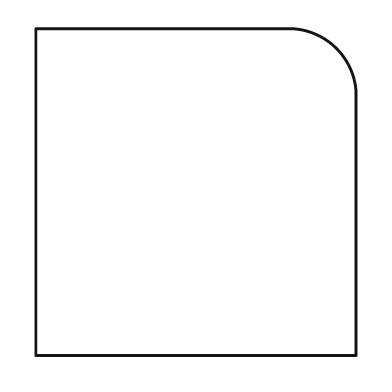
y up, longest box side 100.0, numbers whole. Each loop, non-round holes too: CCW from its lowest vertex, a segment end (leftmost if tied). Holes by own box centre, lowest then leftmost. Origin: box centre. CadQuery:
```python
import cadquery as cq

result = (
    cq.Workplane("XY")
    .moveTo(-49.0, -50.0)
    .lineTo(49.0, -50.0)
    .lineTo(49.0, 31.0)
    .threePointArc((43.0, 44.0), (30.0, 50.0))
    .lineTo(-49.0, 50.0)
    .close()
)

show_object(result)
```